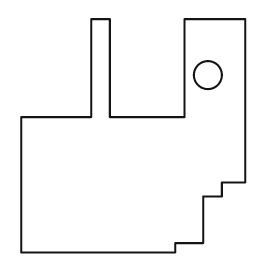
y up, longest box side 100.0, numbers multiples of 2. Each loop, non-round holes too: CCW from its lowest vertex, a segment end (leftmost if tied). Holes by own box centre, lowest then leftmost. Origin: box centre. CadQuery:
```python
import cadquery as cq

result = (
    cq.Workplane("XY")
    .moveTo(-48.0, -50.0)
    .lineTo(18.0, -50.0)
    .lineTo(18.0, -46.0)
    .lineTo(30.0, -46.0)
    .lineTo(30.0, -26.0)
    .lineTo(38.0, -26.0)
    .lineTo(38.0, -20.0)
    .lineTo(48.0, -20.0)
    .lineTo(48.0, 50.0)
    .lineTo(22.0, 50.0)
    .lineTo(22.0, 8.0)
    .lineTo(-10.0, 8.0)
    .lineTo(-10.0, 50.0)
    .lineTo(-18.0, 50.0)
    .lineTo(-18.0, 8.0)
    .lineTo(-48.0, 8.0)
    .close()
    .moveTo(32.0, 26.0)
    .circle(6.0)
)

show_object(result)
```